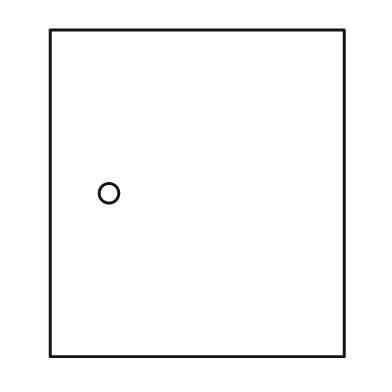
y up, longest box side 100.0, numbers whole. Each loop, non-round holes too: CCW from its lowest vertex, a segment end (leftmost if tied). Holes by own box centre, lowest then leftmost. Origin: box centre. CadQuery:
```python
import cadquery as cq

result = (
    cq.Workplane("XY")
    .moveTo(-45.0, -50.0)
    .lineTo(45.0, -50.0)
    .lineTo(45.0, 50.0)
    .lineTo(-45.0, 50.0)
    .close()
    .moveTo(-27.0, 0.0)
    .circle(3.0)
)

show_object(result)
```